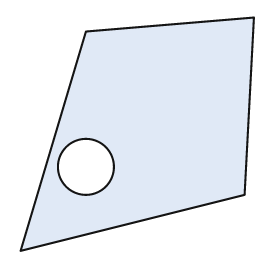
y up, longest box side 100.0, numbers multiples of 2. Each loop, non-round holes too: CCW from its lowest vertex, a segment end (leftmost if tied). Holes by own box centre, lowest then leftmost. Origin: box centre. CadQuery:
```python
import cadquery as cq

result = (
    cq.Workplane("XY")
    .moveTo(-50.0, -50.0)
    .lineTo(46.0, -26.0)
    .lineTo(50.0, 50.0)
    .lineTo(-22.0, 44.0)
    .close()
    .moveTo(-22.0, -14.0)
    .circle(12.0)
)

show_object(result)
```